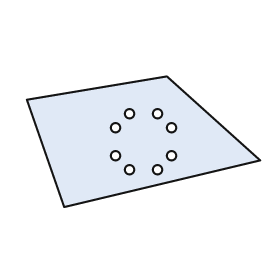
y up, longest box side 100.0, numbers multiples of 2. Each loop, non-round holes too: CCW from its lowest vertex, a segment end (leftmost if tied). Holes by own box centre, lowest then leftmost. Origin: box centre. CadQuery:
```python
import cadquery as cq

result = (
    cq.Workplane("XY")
    .moveTo(-34.0, -28.0)
    .lineTo(50.0, -8.0)
    .lineTo(10.0, 28.0)
    .lineTo(-50.0, 18.0)
    .close()
    .moveTo(-6.0, -12.0)
    .circle(2.0)
    .moveTo(6.0, -12.0)
    .circle(2.0)
    .moveTo(-12.0, -6.0)
    .circle(2.0)
    .moveTo(12.0, -6.0)
    .circle(2.0)
    .moveTo(-12.0, 6.0)
    .circle(2.0)
    .moveTo(12.0, 6.0)
    .circle(2.0)
    .moveTo(-6.0, 12.0)
    .circle(2.0)
    .moveTo(6.0, 12.0)
    .circle(2.0)
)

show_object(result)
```